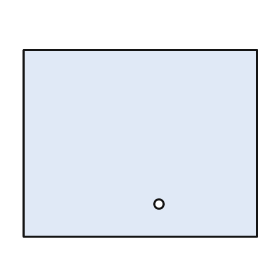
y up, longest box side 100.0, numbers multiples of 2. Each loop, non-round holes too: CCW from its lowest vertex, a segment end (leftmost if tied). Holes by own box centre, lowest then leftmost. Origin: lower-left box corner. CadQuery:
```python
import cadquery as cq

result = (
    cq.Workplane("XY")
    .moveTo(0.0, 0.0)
    .lineTo(100.0, 0.0)
    .lineTo(100.0, 80.0)
    .lineTo(0.0, 80.0)
    .close()
    .moveTo(58.0, 14.0)
    .circle(2.0)
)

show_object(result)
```